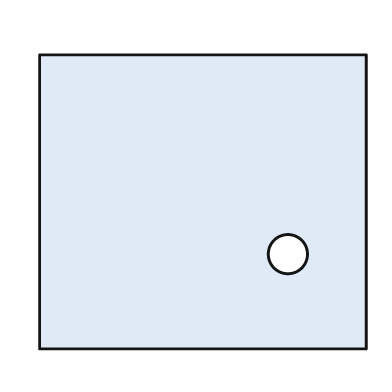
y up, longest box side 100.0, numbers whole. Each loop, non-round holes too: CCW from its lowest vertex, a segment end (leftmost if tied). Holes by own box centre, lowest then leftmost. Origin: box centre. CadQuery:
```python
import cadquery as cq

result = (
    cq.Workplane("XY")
    .moveTo(-50.0, -45.0)
    .lineTo(50.0, -45.0)
    .lineTo(50.0, 45.0)
    .lineTo(-50.0, 45.0)
    .close()
    .moveTo(26.0, -16.0)
    .circle(6.0)
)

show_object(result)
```